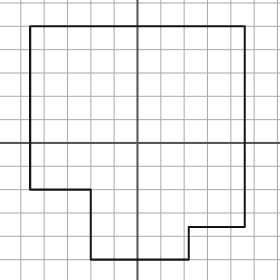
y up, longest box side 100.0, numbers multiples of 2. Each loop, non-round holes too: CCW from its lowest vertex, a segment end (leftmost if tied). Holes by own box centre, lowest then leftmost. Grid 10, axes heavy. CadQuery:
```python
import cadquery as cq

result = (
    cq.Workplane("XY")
    .moveTo(-20.0, -50.0)
    .lineTo(22.0, -50.0)
    .lineTo(22.0, -36.0)
    .lineTo(46.0, -36.0)
    .lineTo(46.0, 50.0)
    .lineTo(-46.0, 50.0)
    .lineTo(-46.0, -20.0)
    .lineTo(-20.0, -20.0)
    .close()
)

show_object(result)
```